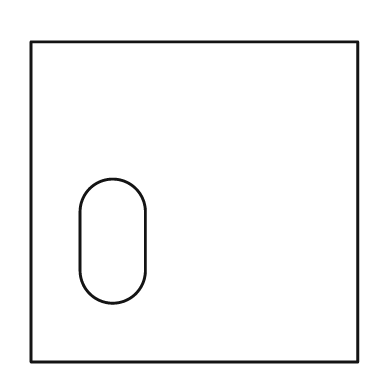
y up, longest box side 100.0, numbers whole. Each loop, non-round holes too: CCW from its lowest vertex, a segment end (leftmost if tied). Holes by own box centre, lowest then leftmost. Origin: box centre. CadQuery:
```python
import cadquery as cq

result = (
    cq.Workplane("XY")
    .moveTo(-50.0, -49.0)
    .lineTo(50.0, -49.0)
    .lineTo(50.0, 49.0)
    .lineTo(-50.0, 49.0)
    .close()
    .moveTo(-35.0, -21.0)
    .threePointArc((-25.0, -31.0), (-15.0, -21.0))
    .lineTo(-15.0, -3.0)
    .threePointArc((-25.0, 7.0), (-35.0, -3.0))
    .close()
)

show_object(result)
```